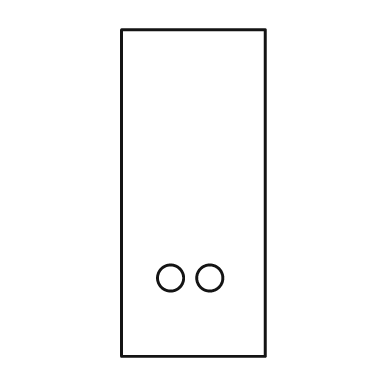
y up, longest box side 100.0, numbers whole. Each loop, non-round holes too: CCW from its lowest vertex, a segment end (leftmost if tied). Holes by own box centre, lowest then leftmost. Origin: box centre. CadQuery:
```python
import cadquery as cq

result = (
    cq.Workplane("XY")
    .moveTo(-22.0, -50.0)
    .lineTo(22.0, -50.0)
    .lineTo(22.0, 50.0)
    .lineTo(-22.0, 50.0)
    .close()
    .moveTo(-7.0, -26.0)
    .circle(4.0)
    .moveTo(5.0, -26.0)
    .circle(4.0)
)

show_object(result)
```